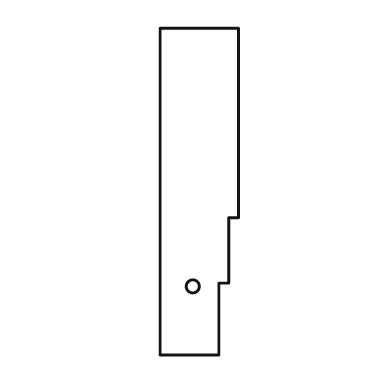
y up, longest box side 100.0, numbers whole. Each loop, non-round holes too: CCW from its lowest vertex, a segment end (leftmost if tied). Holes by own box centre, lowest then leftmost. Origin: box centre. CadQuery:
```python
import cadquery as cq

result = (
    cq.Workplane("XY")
    .moveTo(-12.0, -50.0)
    .lineTo(6.0, -50.0)
    .lineTo(6.0, -28.0)
    .lineTo(9.0, -28.0)
    .lineTo(9.0, -8.0)
    .lineTo(12.0, -8.0)
    .lineTo(12.0, 50.0)
    .lineTo(-12.0, 50.0)
    .close()
    .moveTo(-2.0, -29.0)
    .circle(2.0)
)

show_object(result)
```